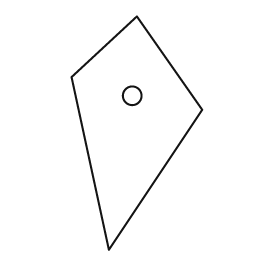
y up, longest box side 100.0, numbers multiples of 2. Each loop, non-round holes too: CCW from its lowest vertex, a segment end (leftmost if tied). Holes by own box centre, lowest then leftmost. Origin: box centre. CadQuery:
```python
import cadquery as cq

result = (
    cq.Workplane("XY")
    .moveTo(-12.0, -50.0)
    .lineTo(28.0, 10.0)
    .lineTo(0.0, 50.0)
    .lineTo(-28.0, 24.0)
    .close()
    .moveTo(-2.0, 16.0)
    .circle(4.0)
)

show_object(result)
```